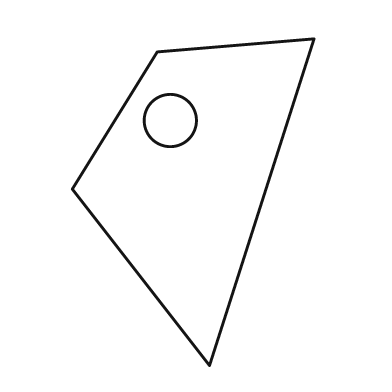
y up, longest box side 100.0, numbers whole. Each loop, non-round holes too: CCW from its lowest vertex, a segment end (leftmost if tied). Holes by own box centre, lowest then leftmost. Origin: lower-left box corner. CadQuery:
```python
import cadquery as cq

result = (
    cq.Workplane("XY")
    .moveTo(42.0, 0.0)
    .lineTo(74.0, 100.0)
    .lineTo(26.0, 96.0)
    .lineTo(0.0, 54.0)
    .close()
    .moveTo(30.0, 75.0)
    .circle(8.0)
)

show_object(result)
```